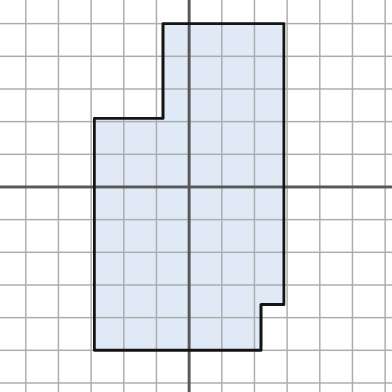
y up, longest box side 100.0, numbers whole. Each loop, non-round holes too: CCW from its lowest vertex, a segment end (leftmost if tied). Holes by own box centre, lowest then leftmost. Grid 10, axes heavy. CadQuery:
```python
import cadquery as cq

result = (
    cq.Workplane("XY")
    .moveTo(-29.0, -50.0)
    .lineTo(22.0, -50.0)
    .lineTo(22.0, -36.0)
    .lineTo(29.0, -36.0)
    .lineTo(29.0, 50.0)
    .lineTo(-8.0, 50.0)
    .lineTo(-8.0, 21.0)
    .lineTo(-29.0, 21.0)
    .close()
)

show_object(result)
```